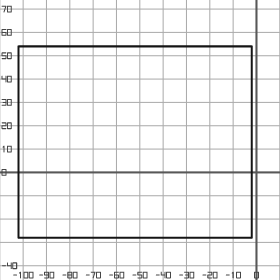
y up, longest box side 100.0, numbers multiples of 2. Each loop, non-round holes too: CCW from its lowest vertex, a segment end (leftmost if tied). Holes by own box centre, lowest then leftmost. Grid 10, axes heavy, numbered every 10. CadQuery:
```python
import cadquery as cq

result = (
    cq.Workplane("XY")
    .moveTo(-102.0, -28.0)
    .lineTo(-2.0, -28.0)
    .lineTo(-2.0, 54.0)
    .lineTo(-102.0, 54.0)
    .close()
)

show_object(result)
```